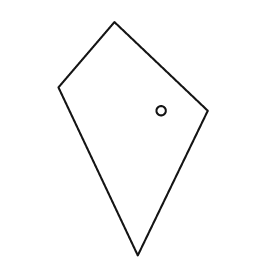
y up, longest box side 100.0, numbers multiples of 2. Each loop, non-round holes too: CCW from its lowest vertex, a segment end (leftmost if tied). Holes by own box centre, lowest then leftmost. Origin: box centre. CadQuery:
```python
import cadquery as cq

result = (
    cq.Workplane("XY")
    .moveTo(2.0, -50.0)
    .lineTo(32.0, 12.0)
    .lineTo(-8.0, 50.0)
    .lineTo(-32.0, 22.0)
    .close()
    .moveTo(12.0, 12.0)
    .circle(2.0)
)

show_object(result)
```